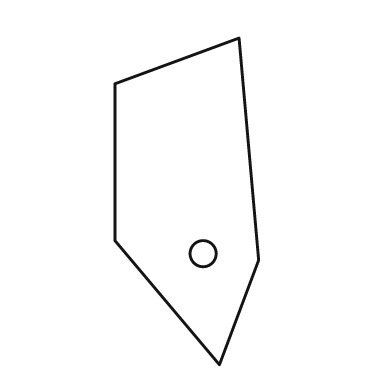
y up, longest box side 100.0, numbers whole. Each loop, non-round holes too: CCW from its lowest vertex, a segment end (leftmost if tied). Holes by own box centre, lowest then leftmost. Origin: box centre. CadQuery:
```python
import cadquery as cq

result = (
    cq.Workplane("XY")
    .moveTo(10.0, -50.0)
    .lineTo(22.0, -18.0)
    .lineTo(16.0, 50.0)
    .lineTo(-22.0, 36.0)
    .lineTo(-22.0, -12.0)
    .close()
    .moveTo(5.0, -16.0)
    .circle(4.0)
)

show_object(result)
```